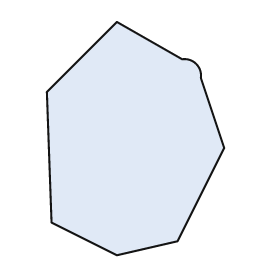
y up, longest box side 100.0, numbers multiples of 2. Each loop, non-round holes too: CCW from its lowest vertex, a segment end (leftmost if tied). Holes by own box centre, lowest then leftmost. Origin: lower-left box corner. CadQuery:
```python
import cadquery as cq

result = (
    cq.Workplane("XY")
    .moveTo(30.0, 0.0)
    .lineTo(56.0, 6.0)
    .lineTo(76.0, 46.0)
    .lineTo(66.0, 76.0)
    .threePointArc((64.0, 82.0), (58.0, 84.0))
    .lineTo(30.0, 100.0)
    .lineTo(0.0, 70.0)
    .lineTo(2.0, 14.0)
    .close()
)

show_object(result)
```